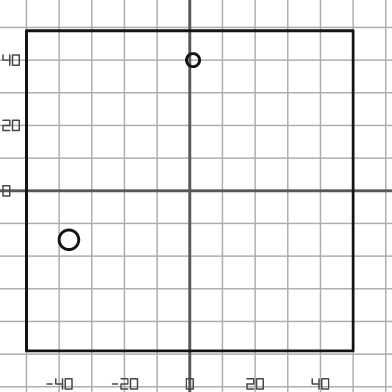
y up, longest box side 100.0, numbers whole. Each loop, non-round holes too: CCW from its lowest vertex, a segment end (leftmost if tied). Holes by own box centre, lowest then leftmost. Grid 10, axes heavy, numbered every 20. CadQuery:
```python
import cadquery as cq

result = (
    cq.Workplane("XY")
    .moveTo(-50.0, -49.0)
    .lineTo(50.0, -49.0)
    .lineTo(50.0, 49.0)
    .lineTo(-50.0, 49.0)
    .close()
    .moveTo(-37.0, -15.0)
    .circle(3.0)
    .moveTo(1.0, 40.0)
    .circle(2.0)
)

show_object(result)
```